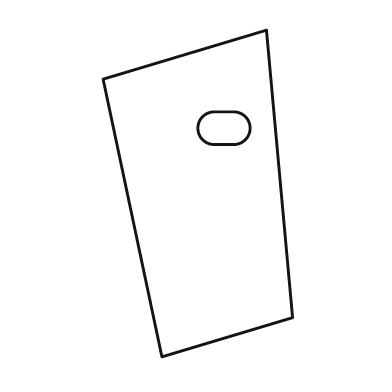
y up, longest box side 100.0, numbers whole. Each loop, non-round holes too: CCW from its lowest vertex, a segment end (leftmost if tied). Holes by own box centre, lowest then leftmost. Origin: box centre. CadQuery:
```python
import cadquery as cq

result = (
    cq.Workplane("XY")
    .moveTo(-11.0, -50.0)
    .lineTo(29.0, -38.0)
    .lineTo(21.0, 50.0)
    .lineTo(-29.0, 35.0)
    .close()
    .moveTo(5.0, 15.0)
    .lineTo(11.0, 15.0)
    .threePointArc((16.0, 20.0), (11.0, 25.0))
    .lineTo(5.0, 25.0)
    .threePointArc((0.0, 20.0), (5.0, 15.0))
    .close()
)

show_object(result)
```